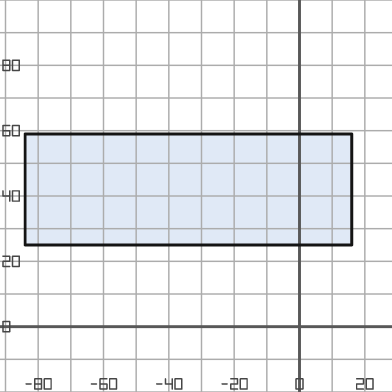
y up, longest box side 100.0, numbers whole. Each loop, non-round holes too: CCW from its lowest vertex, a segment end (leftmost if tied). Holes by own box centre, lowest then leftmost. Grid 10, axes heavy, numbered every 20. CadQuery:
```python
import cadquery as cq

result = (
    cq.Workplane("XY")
    .moveTo(-84.0, 25.0)
    .lineTo(16.0, 25.0)
    .lineTo(16.0, 59.0)
    .lineTo(-84.0, 59.0)
    .close()
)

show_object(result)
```